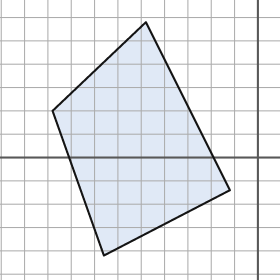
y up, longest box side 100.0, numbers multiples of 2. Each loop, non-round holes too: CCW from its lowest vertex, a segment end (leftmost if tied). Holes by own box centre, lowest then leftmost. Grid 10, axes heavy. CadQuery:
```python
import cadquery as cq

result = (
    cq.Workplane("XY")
    .moveTo(-66.0, -42.0)
    .lineTo(-12.0, -14.0)
    .lineTo(-48.0, 58.0)
    .lineTo(-88.0, 20.0)
    .close()
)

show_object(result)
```